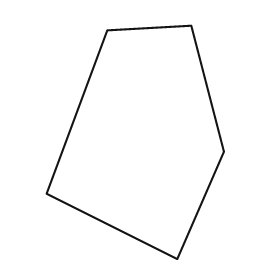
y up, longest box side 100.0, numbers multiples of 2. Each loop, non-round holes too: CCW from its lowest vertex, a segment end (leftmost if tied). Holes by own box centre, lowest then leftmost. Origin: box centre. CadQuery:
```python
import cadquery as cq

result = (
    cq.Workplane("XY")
    .moveTo(18.0, -50.0)
    .lineTo(38.0, -4.0)
    .lineTo(24.0, 50.0)
    .lineTo(-12.0, 48.0)
    .lineTo(-38.0, -22.0)
    .close()
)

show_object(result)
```